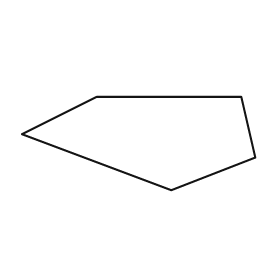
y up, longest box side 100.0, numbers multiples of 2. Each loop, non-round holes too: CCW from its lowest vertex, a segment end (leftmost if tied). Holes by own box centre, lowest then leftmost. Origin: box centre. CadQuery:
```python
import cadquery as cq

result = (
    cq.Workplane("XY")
    .moveTo(14.0, -20.0)
    .lineTo(50.0, -6.0)
    .lineTo(44.0, 20.0)
    .lineTo(-18.0, 20.0)
    .lineTo(-50.0, 4.0)
    .close()
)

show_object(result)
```